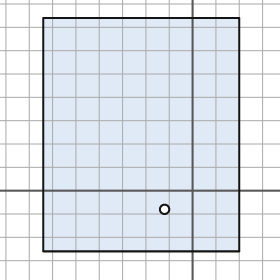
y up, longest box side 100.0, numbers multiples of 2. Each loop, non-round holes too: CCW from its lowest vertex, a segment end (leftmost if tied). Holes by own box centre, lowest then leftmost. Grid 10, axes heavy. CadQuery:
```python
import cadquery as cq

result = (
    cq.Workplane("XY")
    .moveTo(-64.0, -26.0)
    .lineTo(20.0, -26.0)
    .lineTo(20.0, 74.0)
    .lineTo(-64.0, 74.0)
    .close()
    .moveTo(-12.0, -8.0)
    .circle(2.0)
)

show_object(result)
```